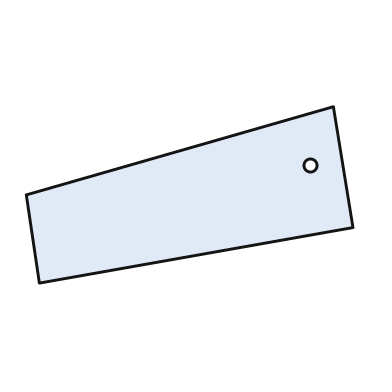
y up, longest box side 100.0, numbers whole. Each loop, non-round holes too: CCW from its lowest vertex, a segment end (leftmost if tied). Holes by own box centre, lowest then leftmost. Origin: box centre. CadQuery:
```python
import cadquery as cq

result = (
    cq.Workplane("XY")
    .moveTo(-46.0, -27.0)
    .lineTo(50.0, -10.0)
    .lineTo(44.0, 27.0)
    .lineTo(-50.0, 0.0)
    .close()
    .moveTo(37.0, 9.0)
    .circle(2.0)
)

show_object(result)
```